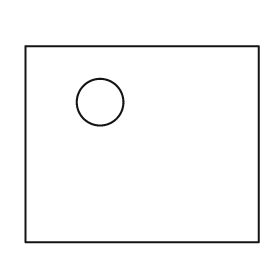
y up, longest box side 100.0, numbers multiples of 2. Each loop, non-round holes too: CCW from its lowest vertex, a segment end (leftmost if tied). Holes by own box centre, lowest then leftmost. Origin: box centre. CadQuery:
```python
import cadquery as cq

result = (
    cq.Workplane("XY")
    .moveTo(-50.0, -42.0)
    .lineTo(50.0, -42.0)
    .lineTo(50.0, 42.0)
    .lineTo(-50.0, 42.0)
    .close()
    .moveTo(-18.0, 18.0)
    .circle(10.0)
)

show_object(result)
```